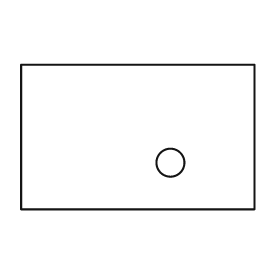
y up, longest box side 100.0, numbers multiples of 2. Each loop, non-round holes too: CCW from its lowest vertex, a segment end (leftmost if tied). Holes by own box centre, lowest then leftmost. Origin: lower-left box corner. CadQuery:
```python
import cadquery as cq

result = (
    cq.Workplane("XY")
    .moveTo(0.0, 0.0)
    .lineTo(100.0, 0.0)
    .lineTo(100.0, 62.0)
    .lineTo(0.0, 62.0)
    .close()
    .moveTo(64.0, 20.0)
    .circle(6.0)
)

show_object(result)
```